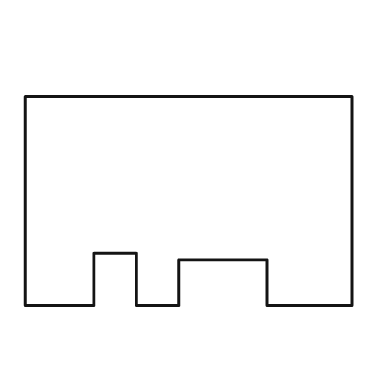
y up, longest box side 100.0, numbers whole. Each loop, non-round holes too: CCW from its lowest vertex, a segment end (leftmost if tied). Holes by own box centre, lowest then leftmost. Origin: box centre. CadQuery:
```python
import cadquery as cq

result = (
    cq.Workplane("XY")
    .moveTo(-50.0, -32.0)
    .lineTo(-29.0, -32.0)
    .lineTo(-29.0, -16.0)
    .lineTo(-16.0, -16.0)
    .lineTo(-16.0, -32.0)
    .lineTo(-3.0, -32.0)
    .lineTo(-3.0, -18.0)
    .lineTo(24.0, -18.0)
    .lineTo(24.0, -32.0)
    .lineTo(50.0, -32.0)
    .lineTo(50.0, 32.0)
    .lineTo(-50.0, 32.0)
    .close()
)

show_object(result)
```